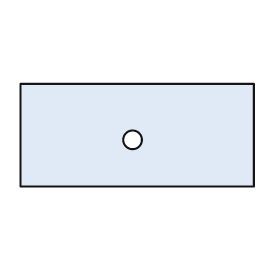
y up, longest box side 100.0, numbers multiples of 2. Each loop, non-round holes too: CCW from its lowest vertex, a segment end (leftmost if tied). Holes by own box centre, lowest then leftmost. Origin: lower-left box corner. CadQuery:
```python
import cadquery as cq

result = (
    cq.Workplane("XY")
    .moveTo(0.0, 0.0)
    .lineTo(100.0, 0.0)
    .lineTo(100.0, 44.0)
    .lineTo(0.0, 44.0)
    .close()
    .moveTo(48.0, 20.0)
    .circle(4.0)
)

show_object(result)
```